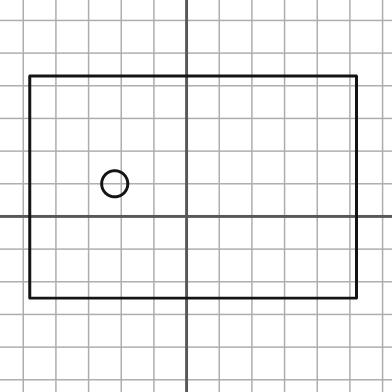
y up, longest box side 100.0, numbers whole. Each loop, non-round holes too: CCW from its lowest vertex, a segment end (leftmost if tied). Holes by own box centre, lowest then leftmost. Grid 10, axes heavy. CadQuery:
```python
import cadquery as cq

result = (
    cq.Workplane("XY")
    .moveTo(-48.0, -25.0)
    .lineTo(52.0, -25.0)
    .lineTo(52.0, 43.0)
    .lineTo(-48.0, 43.0)
    .close()
    .moveTo(-22.0, 10.0)
    .circle(4.0)
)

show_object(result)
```